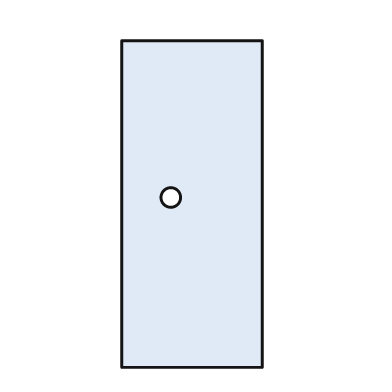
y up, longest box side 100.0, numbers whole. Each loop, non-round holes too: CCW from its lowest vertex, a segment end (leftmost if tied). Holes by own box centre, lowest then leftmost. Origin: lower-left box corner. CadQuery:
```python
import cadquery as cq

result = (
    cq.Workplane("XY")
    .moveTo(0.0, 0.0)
    .lineTo(43.0, 0.0)
    .lineTo(43.0, 100.0)
    .lineTo(0.0, 100.0)
    .close()
    .moveTo(15.0, 52.0)
    .circle(3.0)
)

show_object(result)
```